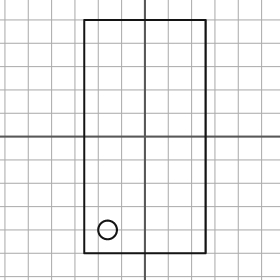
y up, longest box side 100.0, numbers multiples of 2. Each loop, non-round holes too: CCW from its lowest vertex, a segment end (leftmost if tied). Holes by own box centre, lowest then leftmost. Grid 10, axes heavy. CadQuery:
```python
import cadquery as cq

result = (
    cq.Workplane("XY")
    .moveTo(-26.0, -50.0)
    .lineTo(26.0, -50.0)
    .lineTo(26.0, 50.0)
    .lineTo(-26.0, 50.0)
    .close()
    .moveTo(-16.0, -40.0)
    .circle(4.0)
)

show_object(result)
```